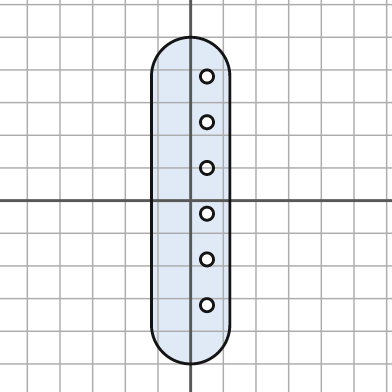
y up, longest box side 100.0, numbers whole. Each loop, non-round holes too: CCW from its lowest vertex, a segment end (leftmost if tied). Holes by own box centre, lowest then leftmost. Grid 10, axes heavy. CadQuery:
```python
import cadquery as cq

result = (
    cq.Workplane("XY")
    .moveTo(-12.0, -38.0)
    .threePointArc((0.0, -50.0), (12.0, -38.0))
    .lineTo(12.0, 38.0)
    .threePointArc((0.0, 50.0), (-12.0, 38.0))
    .close()
    .moveTo(5.0, -32.0)
    .circle(2.0)
    .moveTo(5.0, -18.0)
    .circle(2.0)
    .moveTo(5.0, -4.0)
    .circle(2.0)
    .moveTo(5.0, 10.0)
    .circle(2.0)
    .moveTo(5.0, 24.0)
    .circle(2.0)
    .moveTo(5.0, 38.0)
    .circle(2.0)
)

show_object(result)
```